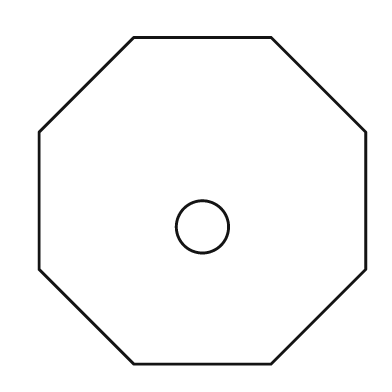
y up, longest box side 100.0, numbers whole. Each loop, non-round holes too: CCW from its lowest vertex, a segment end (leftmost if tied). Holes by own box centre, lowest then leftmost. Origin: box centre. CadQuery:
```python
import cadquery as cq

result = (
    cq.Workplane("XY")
    .moveTo(-21.0, -50.0)
    .lineTo(21.0, -50.0)
    .lineTo(50.0, -21.0)
    .lineTo(50.0, 21.0)
    .lineTo(21.0, 50.0)
    .lineTo(-21.0, 50.0)
    .lineTo(-50.0, 21.0)
    .lineTo(-50.0, -21.0)
    .close()
    .moveTo(0.0, -8.0)
    .circle(8.0)
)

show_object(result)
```